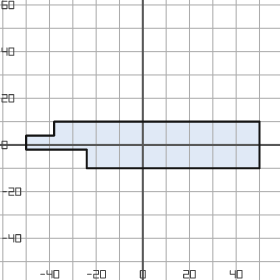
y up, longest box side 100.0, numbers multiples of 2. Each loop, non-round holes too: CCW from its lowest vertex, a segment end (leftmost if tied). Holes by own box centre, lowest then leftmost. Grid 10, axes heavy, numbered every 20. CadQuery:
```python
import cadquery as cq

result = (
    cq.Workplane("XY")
    .moveTo(-24.0, -10.0)
    .lineTo(50.0, -10.0)
    .lineTo(50.0, 10.0)
    .lineTo(-38.0, 10.0)
    .lineTo(-38.0, 4.0)
    .lineTo(-50.0, 4.0)
    .lineTo(-50.0, -2.0)
    .lineTo(-24.0, -2.0)
    .close()
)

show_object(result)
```